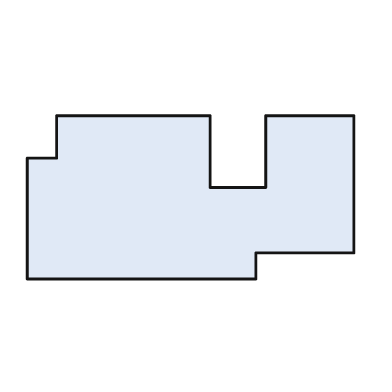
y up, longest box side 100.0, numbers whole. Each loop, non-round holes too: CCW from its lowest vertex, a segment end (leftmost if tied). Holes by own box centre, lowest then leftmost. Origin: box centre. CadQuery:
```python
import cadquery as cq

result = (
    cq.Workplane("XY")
    .moveTo(-50.0, -25.0)
    .lineTo(20.0, -25.0)
    .lineTo(20.0, -17.0)
    .lineTo(50.0, -17.0)
    .lineTo(50.0, 25.0)
    .lineTo(23.0, 25.0)
    .lineTo(23.0, 3.0)
    .lineTo(6.0, 3.0)
    .lineTo(6.0, 25.0)
    .lineTo(-41.0, 25.0)
    .lineTo(-41.0, 12.0)
    .lineTo(-50.0, 12.0)
    .close()
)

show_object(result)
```